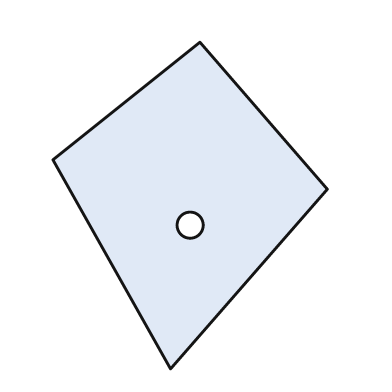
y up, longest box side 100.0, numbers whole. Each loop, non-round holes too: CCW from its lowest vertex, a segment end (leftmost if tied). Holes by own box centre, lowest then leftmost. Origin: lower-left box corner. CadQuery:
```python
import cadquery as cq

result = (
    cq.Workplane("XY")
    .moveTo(36.0, 0.0)
    .lineTo(84.0, 55.0)
    .lineTo(45.0, 100.0)
    .lineTo(0.0, 64.0)
    .close()
    .moveTo(42.0, 44.0)
    .circle(4.0)
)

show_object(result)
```